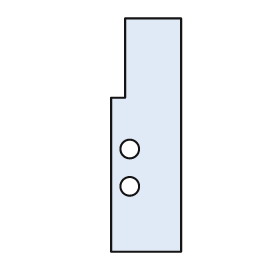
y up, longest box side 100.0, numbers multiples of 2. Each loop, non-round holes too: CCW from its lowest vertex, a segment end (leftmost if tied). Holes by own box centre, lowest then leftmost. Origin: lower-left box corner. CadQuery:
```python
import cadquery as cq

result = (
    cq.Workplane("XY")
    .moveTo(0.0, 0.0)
    .lineTo(30.0, 0.0)
    .lineTo(30.0, 100.0)
    .lineTo(6.0, 100.0)
    .lineTo(6.0, 66.0)
    .lineTo(0.0, 66.0)
    .close()
    .moveTo(8.0, 28.0)
    .circle(4.0)
    .moveTo(8.0, 44.0)
    .circle(4.0)
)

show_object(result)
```